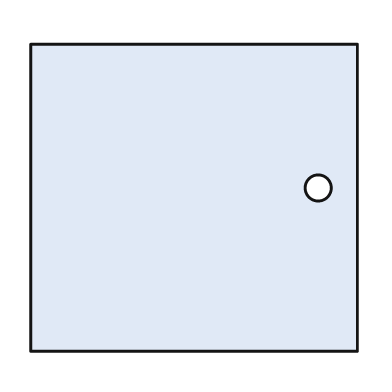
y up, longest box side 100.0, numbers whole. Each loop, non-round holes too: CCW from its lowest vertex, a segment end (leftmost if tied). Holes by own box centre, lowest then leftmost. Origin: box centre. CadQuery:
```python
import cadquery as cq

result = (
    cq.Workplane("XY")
    .moveTo(-50.0, -47.0)
    .lineTo(50.0, -47.0)
    .lineTo(50.0, 47.0)
    .lineTo(-50.0, 47.0)
    .close()
    .moveTo(38.0, 3.0)
    .circle(4.0)
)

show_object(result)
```